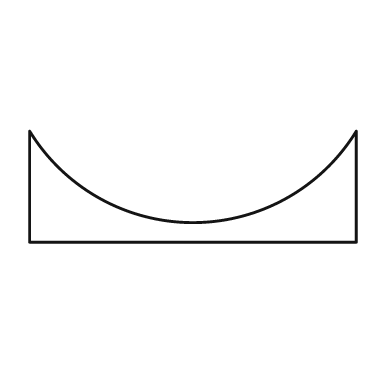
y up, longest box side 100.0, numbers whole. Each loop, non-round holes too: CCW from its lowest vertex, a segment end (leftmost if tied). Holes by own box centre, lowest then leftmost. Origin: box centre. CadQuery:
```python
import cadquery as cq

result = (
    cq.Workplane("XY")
    .moveTo(-50.0, -17.0)
    .lineTo(50.0, -17.0)
    .lineTo(50.0, 17.0)
    .threePointArc((0.0, -11.0), (-50.0, 17.0))
    .close()
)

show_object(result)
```